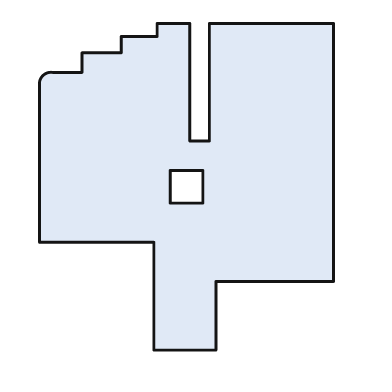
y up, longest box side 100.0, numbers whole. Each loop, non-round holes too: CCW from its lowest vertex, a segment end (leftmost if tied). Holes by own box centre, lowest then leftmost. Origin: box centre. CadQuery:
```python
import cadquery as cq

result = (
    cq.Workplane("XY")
    .moveTo(-10.0, -50.0)
    .lineTo(9.0, -50.0)
    .lineTo(9.0, -29.0)
    .lineTo(45.0, -29.0)
    .lineTo(45.0, 50.0)
    .lineTo(7.0, 50.0)
    .lineTo(7.0, 14.0)
    .lineTo(1.0, 14.0)
    .lineTo(1.0, 50.0)
    .lineTo(-9.0, 50.0)
    .lineTo(-9.0, 46.0)
    .lineTo(-20.0, 46.0)
    .lineTo(-20.0, 41.0)
    .lineTo(-32.0, 41.0)
    .lineTo(-32.0, 35.0)
    .lineTo(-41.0, 35.0)
    .threePointArc((-44.0, 34.0), (-45.0, 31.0))
    .lineTo(-45.0, -17.0)
    .lineTo(-10.0, -17.0)
    .close()
    .moveTo(-5.0, -5.0)
    .lineTo(5.0, -5.0)
    .lineTo(5.0, 5.0)
    .lineTo(-5.0, 5.0)
    .close()
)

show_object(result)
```